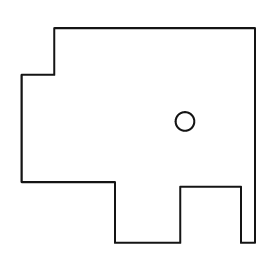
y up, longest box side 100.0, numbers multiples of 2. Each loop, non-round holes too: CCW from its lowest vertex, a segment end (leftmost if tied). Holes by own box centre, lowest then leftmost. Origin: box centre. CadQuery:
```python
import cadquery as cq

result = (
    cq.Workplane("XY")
    .moveTo(-10.0, -46.0)
    .lineTo(18.0, -46.0)
    .lineTo(18.0, -22.0)
    .lineTo(44.0, -22.0)
    .lineTo(44.0, -46.0)
    .lineTo(50.0, -46.0)
    .lineTo(50.0, 46.0)
    .lineTo(-36.0, 46.0)
    .lineTo(-36.0, 26.0)
    .lineTo(-50.0, 26.0)
    .lineTo(-50.0, -20.0)
    .lineTo(-10.0, -20.0)
    .close()
    .moveTo(20.0, 6.0)
    .circle(4.0)
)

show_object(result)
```